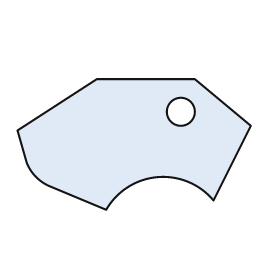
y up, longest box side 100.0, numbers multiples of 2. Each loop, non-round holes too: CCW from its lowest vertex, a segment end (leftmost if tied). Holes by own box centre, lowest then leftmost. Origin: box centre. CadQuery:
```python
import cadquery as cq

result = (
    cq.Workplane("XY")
    .moveTo(-12.0, -28.0)
    .threePointArc((10.0, -14.0), (34.0, -24.0))
    .lineTo(50.0, 8.0)
    .lineTo(26.0, 28.0)
    .lineTo(-16.0, 28.0)
    .lineTo(-50.0, 6.0)
    .lineTo(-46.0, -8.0)
    .threePointArc((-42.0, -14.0), (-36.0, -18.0))
    .close()
    .moveTo(20.0, 14.0)
    .circle(6.0)
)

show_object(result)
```